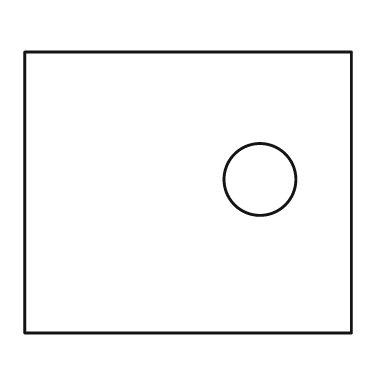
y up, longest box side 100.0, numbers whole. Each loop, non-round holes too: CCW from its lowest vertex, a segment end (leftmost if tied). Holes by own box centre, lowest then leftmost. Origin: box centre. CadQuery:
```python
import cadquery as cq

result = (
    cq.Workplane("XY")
    .moveTo(-50.0, -43.0)
    .lineTo(50.0, -43.0)
    .lineTo(50.0, 43.0)
    .lineTo(-50.0, 43.0)
    .close()
    .moveTo(22.0, 4.0)
    .circle(11.0)
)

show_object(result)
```